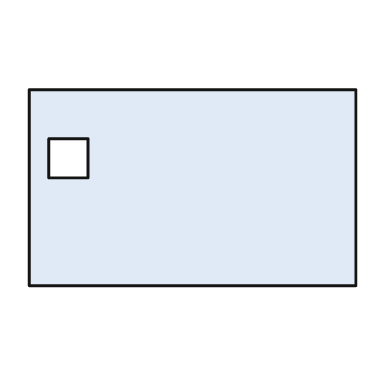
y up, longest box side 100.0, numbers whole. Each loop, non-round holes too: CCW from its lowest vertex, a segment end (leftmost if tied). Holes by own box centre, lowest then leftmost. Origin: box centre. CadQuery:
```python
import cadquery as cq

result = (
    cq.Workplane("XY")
    .moveTo(-50.0, -30.0)
    .lineTo(50.0, -30.0)
    .lineTo(50.0, 30.0)
    .lineTo(-50.0, 30.0)
    .close()
    .moveTo(-44.0, 3.0)
    .lineTo(-32.0, 3.0)
    .lineTo(-32.0, 15.0)
    .lineTo(-44.0, 15.0)
    .close()
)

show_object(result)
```